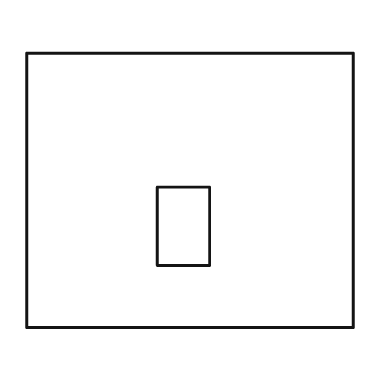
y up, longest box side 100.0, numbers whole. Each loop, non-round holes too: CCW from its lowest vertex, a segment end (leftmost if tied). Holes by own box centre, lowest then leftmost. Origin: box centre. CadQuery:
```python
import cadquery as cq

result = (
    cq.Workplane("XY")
    .moveTo(-50.0, -42.0)
    .lineTo(50.0, -42.0)
    .lineTo(50.0, 42.0)
    .lineTo(-50.0, 42.0)
    .close()
    .moveTo(-10.0, -23.0)
    .lineTo(6.0, -23.0)
    .lineTo(6.0, 1.0)
    .lineTo(-10.0, 1.0)
    .close()
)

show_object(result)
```